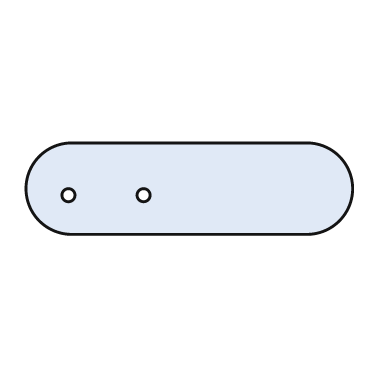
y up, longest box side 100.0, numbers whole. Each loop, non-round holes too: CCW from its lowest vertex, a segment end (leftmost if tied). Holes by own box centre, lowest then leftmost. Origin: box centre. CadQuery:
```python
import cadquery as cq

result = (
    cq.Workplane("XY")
    .moveTo(-36.0, -14.0)
    .lineTo(36.0, -14.0)
    .threePointArc((50.0, 0.0), (36.0, 14.0))
    .lineTo(-36.0, 14.0)
    .threePointArc((-50.0, 0.0), (-36.0, -14.0))
    .close()
    .moveTo(-37.0, -2.0)
    .circle(2.0)
    .moveTo(-14.0, -2.0)
    .circle(2.0)
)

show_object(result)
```